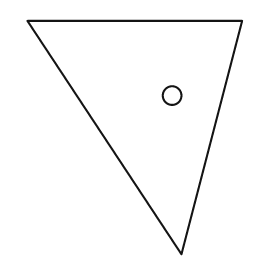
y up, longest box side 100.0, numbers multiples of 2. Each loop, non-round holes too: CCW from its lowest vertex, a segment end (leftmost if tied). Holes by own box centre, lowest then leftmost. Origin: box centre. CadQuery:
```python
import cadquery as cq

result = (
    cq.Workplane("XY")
    .moveTo(20.0, -50.0)
    .lineTo(46.0, 50.0)
    .lineTo(-46.0, 50.0)
    .close()
    .moveTo(16.0, 18.0)
    .circle(4.0)
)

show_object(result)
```